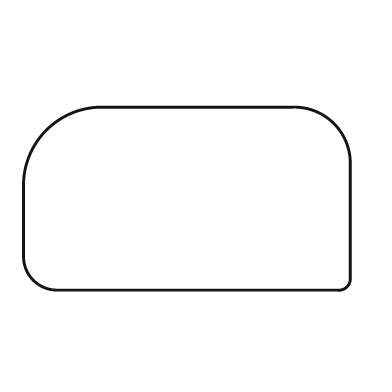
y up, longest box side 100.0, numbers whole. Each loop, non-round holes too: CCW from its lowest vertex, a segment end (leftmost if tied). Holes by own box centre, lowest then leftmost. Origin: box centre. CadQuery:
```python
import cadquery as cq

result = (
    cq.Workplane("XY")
    .moveTo(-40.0, -28.0)
    .lineTo(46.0, -28.0)
    .threePointArc((49.0, -27.0), (50.0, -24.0))
    .lineTo(50.0, 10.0)
    .threePointArc((45.0, 23.0), (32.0, 28.0))
    .lineTo(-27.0, 28.0)
    .threePointArc((-43.0, 21.0), (-50.0, 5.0))
    .lineTo(-50.0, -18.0)
    .threePointArc((-47.0, -25.0), (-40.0, -28.0))
    .close()
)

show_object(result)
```